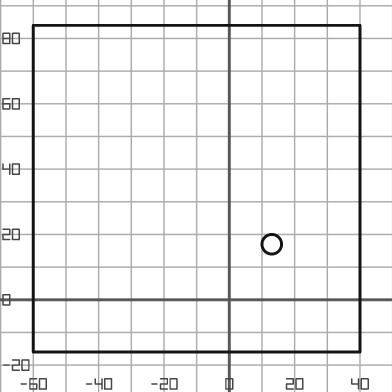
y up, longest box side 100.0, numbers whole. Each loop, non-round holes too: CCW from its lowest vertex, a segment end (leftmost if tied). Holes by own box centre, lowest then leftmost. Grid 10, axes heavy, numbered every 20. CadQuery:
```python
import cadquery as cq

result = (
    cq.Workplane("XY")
    .moveTo(-60.0, -16.0)
    .lineTo(40.0, -16.0)
    .lineTo(40.0, 84.0)
    .lineTo(-60.0, 84.0)
    .close()
    .moveTo(13.0, 17.0)
    .circle(3.0)
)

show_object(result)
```